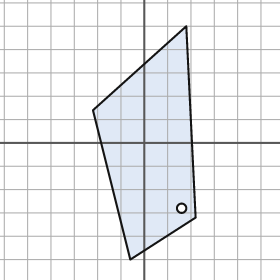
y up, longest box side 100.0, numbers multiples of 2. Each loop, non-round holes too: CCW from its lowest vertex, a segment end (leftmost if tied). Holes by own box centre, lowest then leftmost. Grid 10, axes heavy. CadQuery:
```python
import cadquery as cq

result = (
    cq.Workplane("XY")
    .moveTo(-6.0, -50.0)
    .lineTo(22.0, -32.0)
    .lineTo(18.0, 50.0)
    .lineTo(-22.0, 14.0)
    .close()
    .moveTo(16.0, -28.0)
    .circle(2.0)
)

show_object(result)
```